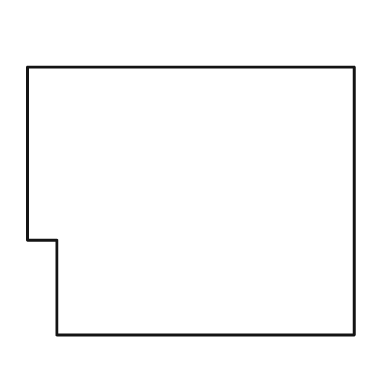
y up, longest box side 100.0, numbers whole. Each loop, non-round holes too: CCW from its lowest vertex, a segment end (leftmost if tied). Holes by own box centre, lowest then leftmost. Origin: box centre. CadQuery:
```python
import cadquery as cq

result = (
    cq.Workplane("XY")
    .moveTo(-41.0, -41.0)
    .lineTo(50.0, -41.0)
    .lineTo(50.0, 41.0)
    .lineTo(-50.0, 41.0)
    .lineTo(-50.0, -12.0)
    .lineTo(-41.0, -12.0)
    .close()
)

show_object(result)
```